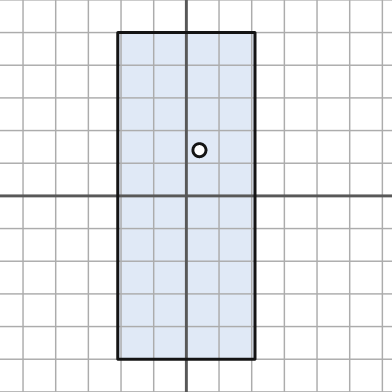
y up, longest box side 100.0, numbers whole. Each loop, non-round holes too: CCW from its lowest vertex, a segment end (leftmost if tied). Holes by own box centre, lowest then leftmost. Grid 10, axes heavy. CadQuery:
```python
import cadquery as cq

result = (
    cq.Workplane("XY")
    .moveTo(-21.0, -50.0)
    .lineTo(21.0, -50.0)
    .lineTo(21.0, 50.0)
    .lineTo(-21.0, 50.0)
    .close()
    .moveTo(4.0, 14.0)
    .circle(2.0)
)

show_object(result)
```